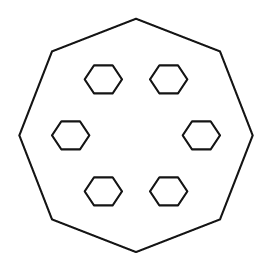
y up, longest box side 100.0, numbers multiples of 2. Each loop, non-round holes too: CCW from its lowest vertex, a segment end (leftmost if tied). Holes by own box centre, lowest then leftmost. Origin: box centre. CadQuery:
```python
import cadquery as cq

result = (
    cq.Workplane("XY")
    .moveTo(0.0, -50.0)
    .lineTo(36.0, -36.0)
    .lineTo(50.0, 0.0)
    .lineTo(36.0, 36.0)
    .lineTo(0.0, 50.0)
    .lineTo(-36.0, 36.0)
    .lineTo(-50.0, 0.0)
    .lineTo(-36.0, -36.0)
    .close()
    .moveTo(-18.0, -30.0)
    .lineTo(-10.0, -30.0)
    .lineTo(-6.0, -24.0)
    .lineTo(-10.0, -18.0)
    .lineTo(-18.0, -18.0)
    .lineTo(-22.0, -24.0)
    .close()
    .moveTo(10.0, -30.0)
    .lineTo(18.0, -30.0)
    .lineTo(22.0, -24.0)
    .lineTo(18.0, -18.0)
    .lineTo(10.0, -18.0)
    .lineTo(6.0, -24.0)
    .close()
    .moveTo(-32.0, -6.0)
    .lineTo(-24.0, -6.0)
    .lineTo(-20.0, 0.0)
    .lineTo(-24.0, 6.0)
    .lineTo(-32.0, 6.0)
    .lineTo(-36.0, 0.0)
    .close()
    .moveTo(24.0, -6.0)
    .lineTo(32.0, -6.0)
    .lineTo(36.0, 0.0)
    .lineTo(32.0, 6.0)
    .lineTo(24.0, 6.0)
    .lineTo(20.0, 0.0)
    .close()
    .moveTo(-18.0, 18.0)
    .lineTo(-10.0, 18.0)
    .lineTo(-6.0, 24.0)
    .lineTo(-10.0, 30.0)
    .lineTo(-18.0, 30.0)
    .lineTo(-22.0, 24.0)
    .close()
    .moveTo(10.0, 18.0)
    .lineTo(18.0, 18.0)
    .lineTo(22.0, 24.0)
    .lineTo(18.0, 30.0)
    .lineTo(10.0, 30.0)
    .lineTo(6.0, 24.0)
    .close()
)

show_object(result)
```